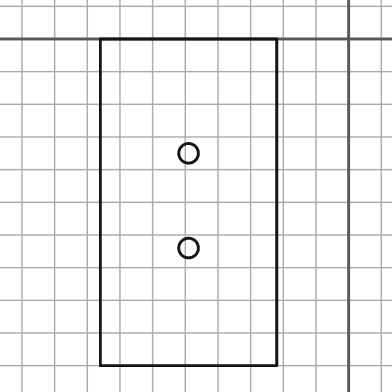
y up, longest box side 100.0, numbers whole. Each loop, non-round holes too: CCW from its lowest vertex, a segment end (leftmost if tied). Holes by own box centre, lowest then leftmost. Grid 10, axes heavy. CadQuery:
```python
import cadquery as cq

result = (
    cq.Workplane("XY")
    .moveTo(-76.0, -100.0)
    .lineTo(-22.0, -100.0)
    .lineTo(-22.0, 0.0)
    .lineTo(-76.0, 0.0)
    .close()
    .moveTo(-49.0, -64.0)
    .circle(3.0)
    .moveTo(-49.0, -35.0)
    .circle(3.0)
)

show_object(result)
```